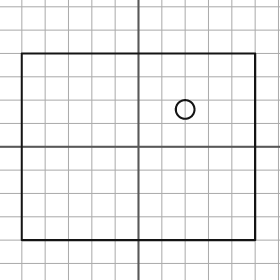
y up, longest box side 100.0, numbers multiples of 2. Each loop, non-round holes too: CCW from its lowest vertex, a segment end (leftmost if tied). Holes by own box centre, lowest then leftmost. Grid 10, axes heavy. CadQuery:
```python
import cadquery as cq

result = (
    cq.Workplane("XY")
    .moveTo(-50.0, -40.0)
    .lineTo(50.0, -40.0)
    .lineTo(50.0, 40.0)
    .lineTo(-50.0, 40.0)
    .close()
    .moveTo(20.0, 16.0)
    .circle(4.0)
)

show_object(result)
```